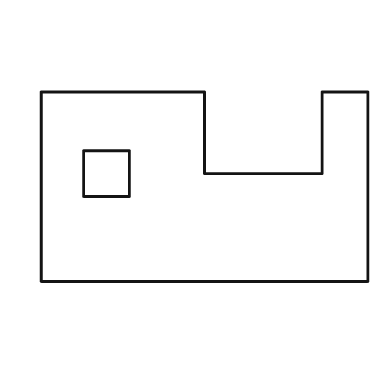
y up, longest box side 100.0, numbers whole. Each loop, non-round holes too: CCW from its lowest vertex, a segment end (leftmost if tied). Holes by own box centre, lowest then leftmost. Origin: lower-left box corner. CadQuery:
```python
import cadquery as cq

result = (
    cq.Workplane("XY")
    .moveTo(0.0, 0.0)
    .lineTo(100.0, 0.0)
    .lineTo(100.0, 58.0)
    .lineTo(86.0, 58.0)
    .lineTo(86.0, 33.0)
    .lineTo(50.0, 33.0)
    .lineTo(50.0, 58.0)
    .lineTo(0.0, 58.0)
    .close()
    .moveTo(13.0, 26.0)
    .lineTo(27.0, 26.0)
    .lineTo(27.0, 40.0)
    .lineTo(13.0, 40.0)
    .close()
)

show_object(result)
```